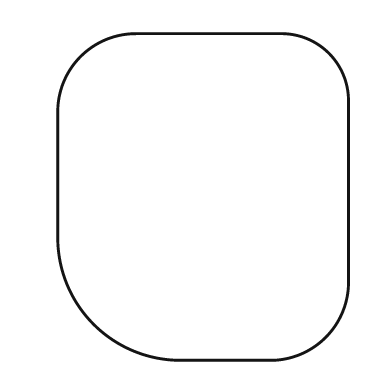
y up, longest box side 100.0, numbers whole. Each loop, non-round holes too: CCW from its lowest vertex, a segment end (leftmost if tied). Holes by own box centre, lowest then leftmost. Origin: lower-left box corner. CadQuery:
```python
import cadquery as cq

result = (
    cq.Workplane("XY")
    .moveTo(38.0, 0.0)
    .lineTo(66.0, 0.0)
    .threePointArc((82.0, 7.0), (89.0, 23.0))
    .lineTo(89.0, 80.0)
    .threePointArc((83.0, 94.0), (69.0, 100.0))
    .lineTo(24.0, 100.0)
    .threePointArc((7.0, 93.0), (0.0, 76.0))
    .lineTo(0.0, 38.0)
    .threePointArc((11.0, 11.0), (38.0, 0.0))
    .close()
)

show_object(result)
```